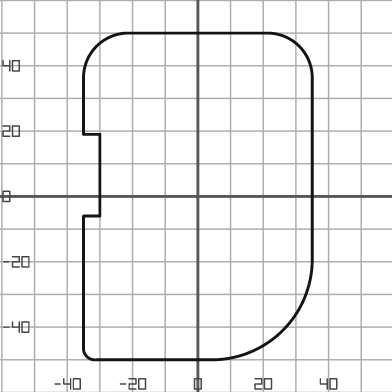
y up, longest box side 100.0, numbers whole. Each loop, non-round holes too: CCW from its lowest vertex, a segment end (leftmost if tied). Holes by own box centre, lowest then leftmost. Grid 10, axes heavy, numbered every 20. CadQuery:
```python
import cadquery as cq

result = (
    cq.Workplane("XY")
    .moveTo(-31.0, -50.0)
    .lineTo(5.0, -50.0)
    .threePointArc((26.0, -41.0), (35.0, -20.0))
    .lineTo(35.0, 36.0)
    .threePointArc((31.0, 46.0), (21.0, 50.0))
    .lineTo(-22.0, 50.0)
    .threePointArc((-31.0, 46.0), (-35.0, 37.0))
    .lineTo(-35.0, 19.0)
    .lineTo(-30.0, 19.0)
    .lineTo(-30.0, -6.0)
    .lineTo(-35.0, -6.0)
    .lineTo(-35.0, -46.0)
    .threePointArc((-34.0, -49.0), (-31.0, -50.0))
    .close()
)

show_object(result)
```